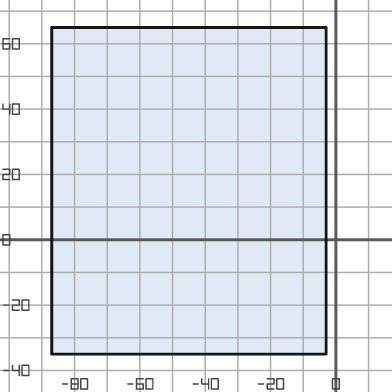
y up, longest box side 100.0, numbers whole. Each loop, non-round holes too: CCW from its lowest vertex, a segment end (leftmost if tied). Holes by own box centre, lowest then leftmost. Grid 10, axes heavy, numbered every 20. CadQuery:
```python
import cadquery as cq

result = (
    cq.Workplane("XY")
    .moveTo(-87.0, -35.0)
    .lineTo(-3.0, -35.0)
    .lineTo(-3.0, 65.0)
    .lineTo(-87.0, 65.0)
    .close()
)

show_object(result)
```